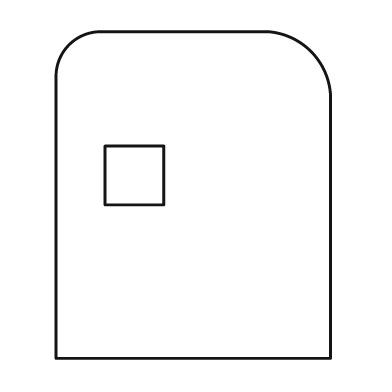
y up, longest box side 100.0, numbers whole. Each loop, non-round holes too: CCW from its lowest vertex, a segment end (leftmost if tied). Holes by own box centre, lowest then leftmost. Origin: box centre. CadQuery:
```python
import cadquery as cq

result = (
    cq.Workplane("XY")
    .moveTo(-42.0, -50.0)
    .lineTo(42.0, -50.0)
    .lineTo(42.0, 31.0)
    .threePointArc((36.0, 44.0), (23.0, 50.0))
    .lineTo(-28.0, 50.0)
    .threePointArc((-38.0, 46.0), (-42.0, 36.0))
    .close()
    .moveTo(-27.0, -3.0)
    .lineTo(-9.0, -3.0)
    .lineTo(-9.0, 15.0)
    .lineTo(-27.0, 15.0)
    .close()
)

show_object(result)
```